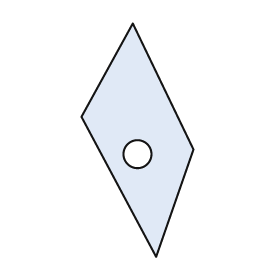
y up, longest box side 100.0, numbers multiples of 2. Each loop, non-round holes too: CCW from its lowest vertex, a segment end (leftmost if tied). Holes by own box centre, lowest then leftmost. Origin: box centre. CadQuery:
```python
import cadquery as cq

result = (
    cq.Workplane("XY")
    .moveTo(8.0, -50.0)
    .lineTo(24.0, -4.0)
    .lineTo(-2.0, 50.0)
    .lineTo(-24.0, 10.0)
    .close()
    .moveTo(0.0, -6.0)
    .circle(6.0)
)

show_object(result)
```